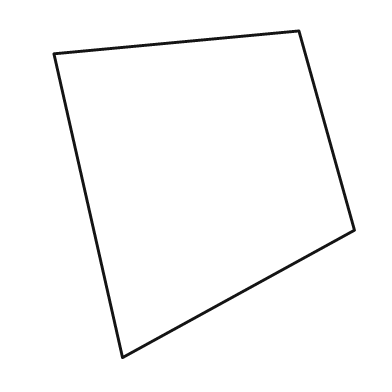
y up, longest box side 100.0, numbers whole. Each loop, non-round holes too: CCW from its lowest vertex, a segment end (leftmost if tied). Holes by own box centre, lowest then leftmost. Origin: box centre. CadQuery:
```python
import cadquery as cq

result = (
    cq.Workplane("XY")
    .moveTo(-25.0, -50.0)
    .lineTo(46.0, -11.0)
    .lineTo(29.0, 50.0)
    .lineTo(-46.0, 43.0)
    .close()
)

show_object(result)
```